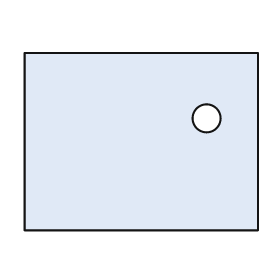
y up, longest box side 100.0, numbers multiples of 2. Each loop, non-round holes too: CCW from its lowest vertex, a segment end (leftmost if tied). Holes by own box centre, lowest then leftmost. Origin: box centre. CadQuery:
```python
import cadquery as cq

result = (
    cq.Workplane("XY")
    .moveTo(-50.0, -38.0)
    .lineTo(50.0, -38.0)
    .lineTo(50.0, 38.0)
    .lineTo(-50.0, 38.0)
    .close()
    .moveTo(28.0, 10.0)
    .circle(6.0)
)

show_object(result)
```